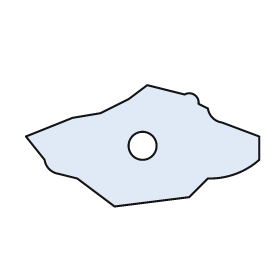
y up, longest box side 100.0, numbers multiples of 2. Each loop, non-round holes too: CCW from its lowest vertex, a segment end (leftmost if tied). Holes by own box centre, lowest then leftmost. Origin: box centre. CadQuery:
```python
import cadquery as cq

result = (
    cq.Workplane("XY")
    .moveTo(-12.0, -26.0)
    .lineTo(20.0, -22.0)
    .lineTo(28.0, -14.0)
    .threePointArc((40.0, -12.0), (50.0, -6.0))
    .lineTo(50.0, 4.0)
    .lineTo(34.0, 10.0)
    .threePointArc((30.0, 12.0), (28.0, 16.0))
    .lineTo(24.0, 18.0)
    .threePointArc((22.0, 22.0), (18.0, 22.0))
    .lineTo(2.0, 26.0)
    .lineTo(-6.0, 20.0)
    .lineTo(-18.0, 14.0)
    .lineTo(-30.0, 12.0)
    .lineTo(-50.0, 4.0)
    .lineTo(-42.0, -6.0)
    .threePointArc((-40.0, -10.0), (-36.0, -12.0))
    .lineTo(-28.0, -14.0)
    .close()
    .moveTo(0.0, 0.0)
    .circle(6.0)
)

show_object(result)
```